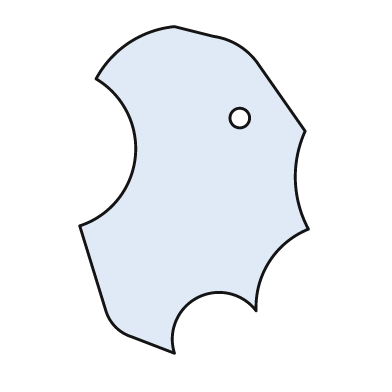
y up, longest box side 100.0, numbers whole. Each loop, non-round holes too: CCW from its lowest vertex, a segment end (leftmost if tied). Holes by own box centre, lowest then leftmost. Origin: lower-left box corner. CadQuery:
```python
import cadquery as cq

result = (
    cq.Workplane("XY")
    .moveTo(29.0, 0.0)
    .threePointArc((36.0, 17.0), (54.0, 13.0))
    .threePointArc((58.0, 28.0), (70.0, 38.0))
    .threePointArc((66.0, 53.0), (69.0, 68.0))
    .lineTo(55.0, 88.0)
    .threePointArc((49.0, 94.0), (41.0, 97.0))
    .lineTo(29.0, 100.0)
    .threePointArc((15.0, 95.0), (5.0, 84.0))
    .threePointArc((17.0, 60.0), (0.0, 39.0))
    .lineTo(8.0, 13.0)
    .threePointArc((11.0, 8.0), (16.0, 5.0))
    .close()
    .moveTo(49.0, 72.0)
    .circle(3.0)
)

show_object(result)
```